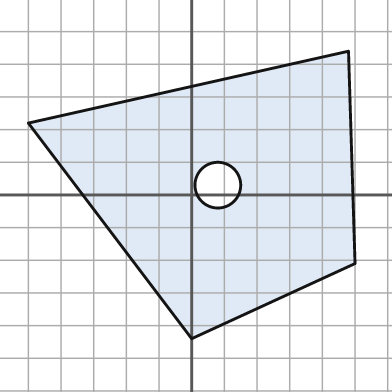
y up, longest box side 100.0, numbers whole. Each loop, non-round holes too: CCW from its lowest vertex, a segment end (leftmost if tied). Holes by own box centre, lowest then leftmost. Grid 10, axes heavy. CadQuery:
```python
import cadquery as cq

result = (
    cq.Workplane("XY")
    .moveTo(0.0, -44.0)
    .lineTo(50.0, -21.0)
    .lineTo(48.0, 44.0)
    .lineTo(-50.0, 22.0)
    .close()
    .moveTo(8.0, 3.0)
    .circle(7.0)
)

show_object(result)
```